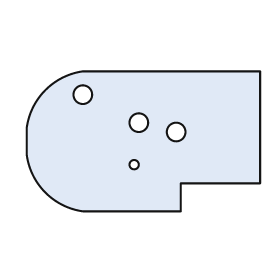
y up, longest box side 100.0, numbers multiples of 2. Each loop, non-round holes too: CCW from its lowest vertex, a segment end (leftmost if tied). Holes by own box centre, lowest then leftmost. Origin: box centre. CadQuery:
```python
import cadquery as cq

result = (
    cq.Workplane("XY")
    .moveTo(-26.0, -30.0)
    .lineTo(16.0, -30.0)
    .lineTo(16.0, -18.0)
    .lineTo(50.0, -18.0)
    .lineTo(50.0, 30.0)
    .lineTo(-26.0, 30.0)
    .threePointArc((-42.0, 22.0), (-50.0, 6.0))
    .lineTo(-50.0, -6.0)
    .threePointArc((-42.0, -22.0), (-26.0, -30.0))
    .close()
    .moveTo(-4.0, -10.0)
    .circle(2.0)
    .moveTo(14.0, 4.0)
    .circle(4.0)
    .moveTo(-2.0, 8.0)
    .circle(4.0)
    .moveTo(-26.0, 20.0)
    .circle(4.0)
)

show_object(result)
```